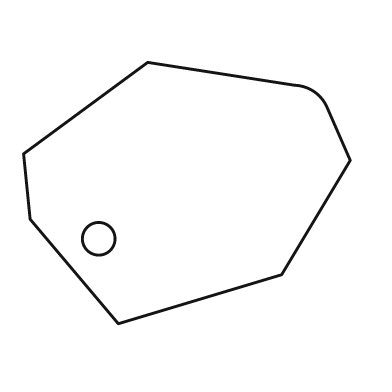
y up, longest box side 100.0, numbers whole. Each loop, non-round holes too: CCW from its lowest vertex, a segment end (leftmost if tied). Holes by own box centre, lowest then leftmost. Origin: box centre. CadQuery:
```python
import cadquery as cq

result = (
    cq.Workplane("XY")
    .moveTo(-21.0, -40.0)
    .lineTo(29.0, -25.0)
    .lineTo(50.0, 10.0)
    .lineTo(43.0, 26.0)
    .threePointArc((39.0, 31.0), (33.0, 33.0))
    .lineTo(-12.0, 40.0)
    .lineTo(-50.0, 12.0)
    .lineTo(-48.0, -8.0)
    .close()
    .moveTo(-27.0, -14.0)
    .circle(5.0)
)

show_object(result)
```